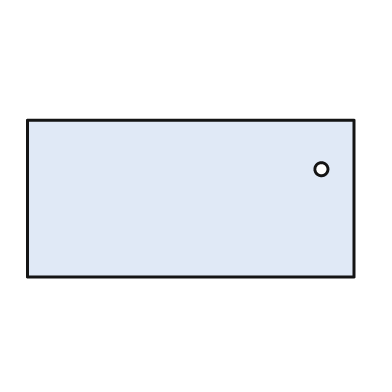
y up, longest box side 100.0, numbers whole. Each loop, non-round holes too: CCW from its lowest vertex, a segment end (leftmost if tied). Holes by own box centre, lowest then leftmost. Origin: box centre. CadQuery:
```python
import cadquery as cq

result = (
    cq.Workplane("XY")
    .moveTo(-50.0, -24.0)
    .lineTo(50.0, -24.0)
    .lineTo(50.0, 24.0)
    .lineTo(-50.0, 24.0)
    .close()
    .moveTo(40.0, 9.0)
    .circle(2.0)
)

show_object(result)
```